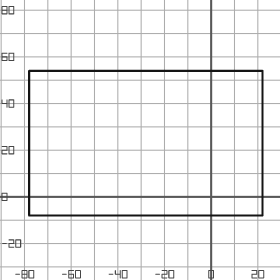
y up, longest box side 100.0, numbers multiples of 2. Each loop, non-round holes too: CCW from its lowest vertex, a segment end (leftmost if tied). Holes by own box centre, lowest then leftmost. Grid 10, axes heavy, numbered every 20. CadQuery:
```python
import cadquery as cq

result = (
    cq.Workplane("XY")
    .moveTo(-78.0, -8.0)
    .lineTo(22.0, -8.0)
    .lineTo(22.0, 54.0)
    .lineTo(-78.0, 54.0)
    .close()
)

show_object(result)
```